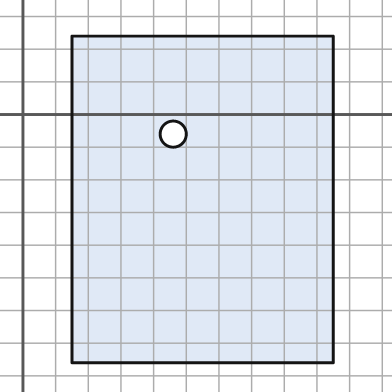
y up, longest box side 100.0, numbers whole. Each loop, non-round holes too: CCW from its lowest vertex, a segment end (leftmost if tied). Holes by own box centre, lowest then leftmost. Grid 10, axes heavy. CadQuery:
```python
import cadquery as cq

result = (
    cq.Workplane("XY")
    .moveTo(15.0, -76.0)
    .lineTo(95.0, -76.0)
    .lineTo(95.0, 24.0)
    .lineTo(15.0, 24.0)
    .close()
    .moveTo(46.0, -6.0)
    .circle(4.0)
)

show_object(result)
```